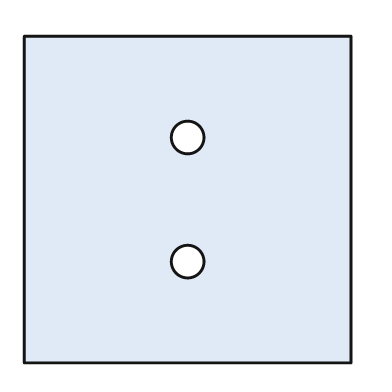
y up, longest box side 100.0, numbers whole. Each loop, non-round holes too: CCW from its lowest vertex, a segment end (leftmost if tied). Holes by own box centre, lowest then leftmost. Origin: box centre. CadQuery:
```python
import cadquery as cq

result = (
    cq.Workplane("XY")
    .moveTo(-50.0, -50.0)
    .lineTo(50.0, -50.0)
    .lineTo(50.0, 50.0)
    .lineTo(-50.0, 50.0)
    .close()
    .moveTo(0.0, -19.0)
    .circle(5.0)
    .moveTo(0.0, 19.0)
    .circle(5.0)
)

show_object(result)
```